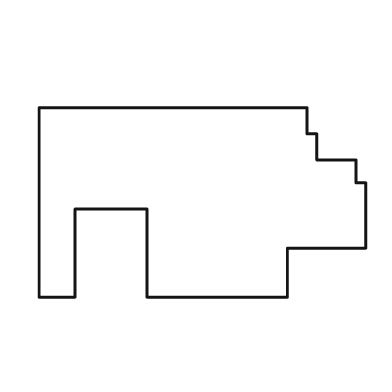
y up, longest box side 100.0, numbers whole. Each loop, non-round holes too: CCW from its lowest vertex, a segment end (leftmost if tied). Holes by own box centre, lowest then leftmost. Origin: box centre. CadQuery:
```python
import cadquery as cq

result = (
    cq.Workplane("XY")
    .moveTo(-50.0, -29.0)
    .lineTo(-39.0, -29.0)
    .lineTo(-39.0, -2.0)
    .lineTo(-17.0, -2.0)
    .lineTo(-17.0, -29.0)
    .lineTo(26.0, -29.0)
    .lineTo(26.0, -14.0)
    .lineTo(50.0, -14.0)
    .lineTo(50.0, 6.0)
    .lineTo(47.0, 6.0)
    .lineTo(47.0, 13.0)
    .lineTo(35.0, 13.0)
    .lineTo(35.0, 21.0)
    .lineTo(32.0, 21.0)
    .lineTo(32.0, 29.0)
    .lineTo(-50.0, 29.0)
    .close()
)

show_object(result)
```